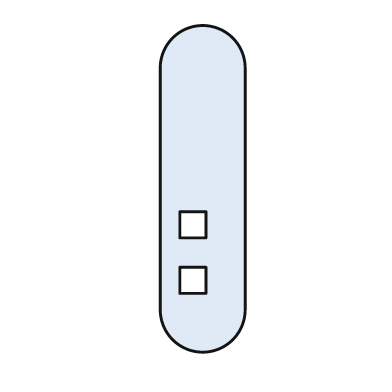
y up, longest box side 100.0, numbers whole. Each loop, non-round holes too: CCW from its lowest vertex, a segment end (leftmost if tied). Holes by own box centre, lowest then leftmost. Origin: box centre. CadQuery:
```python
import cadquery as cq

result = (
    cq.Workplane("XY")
    .moveTo(-13.0, -37.0)
    .threePointArc((0.0, -50.0), (13.0, -37.0))
    .lineTo(13.0, 37.0)
    .threePointArc((0.0, 50.0), (-13.0, 37.0))
    .close()
    .moveTo(-7.0, -32.0)
    .lineTo(1.0, -32.0)
    .lineTo(1.0, -24.0)
    .lineTo(-7.0, -24.0)
    .close()
    .moveTo(-7.0, -15.0)
    .lineTo(1.0, -15.0)
    .lineTo(1.0, -7.0)
    .lineTo(-7.0, -7.0)
    .close()
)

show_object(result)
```